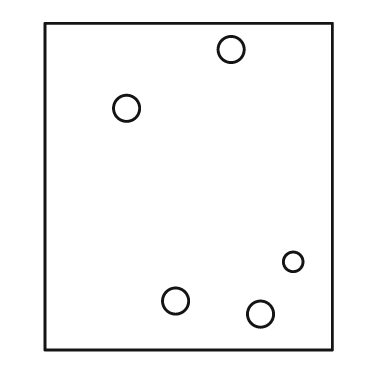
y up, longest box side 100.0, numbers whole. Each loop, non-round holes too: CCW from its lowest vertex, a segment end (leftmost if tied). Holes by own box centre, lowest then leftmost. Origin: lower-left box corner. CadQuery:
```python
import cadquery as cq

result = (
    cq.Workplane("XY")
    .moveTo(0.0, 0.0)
    .lineTo(88.0, 0.0)
    .lineTo(88.0, 100.0)
    .lineTo(0.0, 100.0)
    .close()
    .moveTo(66.0, 11.0)
    .circle(4.0)
    .moveTo(40.0, 15.0)
    .circle(4.0)
    .moveTo(76.0, 27.0)
    .circle(3.0)
    .moveTo(25.0, 74.0)
    .circle(4.0)
    .moveTo(57.0, 92.0)
    .circle(4.0)
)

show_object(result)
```